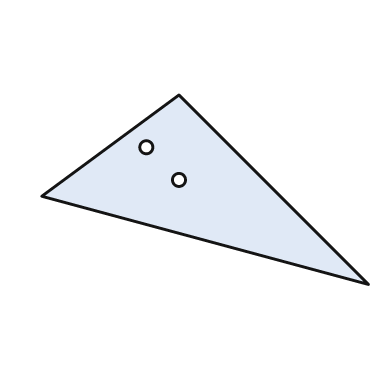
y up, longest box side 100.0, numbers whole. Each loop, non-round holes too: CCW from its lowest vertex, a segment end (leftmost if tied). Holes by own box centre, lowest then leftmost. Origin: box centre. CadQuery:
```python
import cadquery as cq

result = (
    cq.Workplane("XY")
    .moveTo(50.0, -29.0)
    .lineTo(-8.0, 29.0)
    .lineTo(-50.0, -2.0)
    .close()
    .moveTo(-8.0, 3.0)
    .circle(2.0)
    .moveTo(-18.0, 13.0)
    .circle(2.0)
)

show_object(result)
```